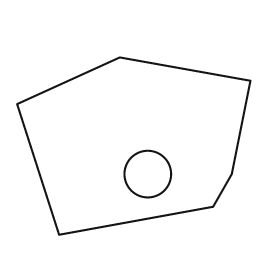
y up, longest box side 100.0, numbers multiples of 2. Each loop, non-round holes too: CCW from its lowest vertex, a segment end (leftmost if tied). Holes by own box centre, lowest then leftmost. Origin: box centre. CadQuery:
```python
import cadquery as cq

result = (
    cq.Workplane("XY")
    .moveTo(-32.0, -38.0)
    .lineTo(34.0, -26.0)
    .lineTo(42.0, -12.0)
    .lineTo(50.0, 28.0)
    .lineTo(-6.0, 38.0)
    .lineTo(-50.0, 18.0)
    .close()
    .moveTo(6.0, -12.0)
    .circle(10.0)
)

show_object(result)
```